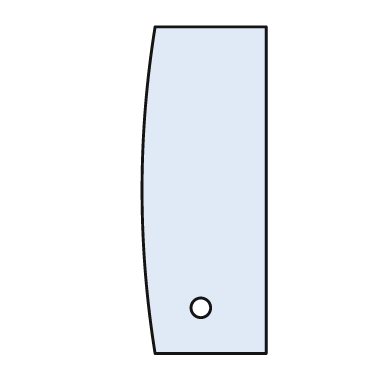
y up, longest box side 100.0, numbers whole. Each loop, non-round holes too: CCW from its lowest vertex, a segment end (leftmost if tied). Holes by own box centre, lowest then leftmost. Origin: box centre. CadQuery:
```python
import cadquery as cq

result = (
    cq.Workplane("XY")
    .moveTo(-15.0, -50.0)
    .lineTo(19.0, -50.0)
    .lineTo(19.0, 50.0)
    .lineTo(-15.0, 50.0)
    .threePointArc((-19.0, 0.0), (-15.0, -50.0))
    .close()
    .moveTo(-1.0, -36.0)
    .circle(3.0)
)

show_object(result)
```